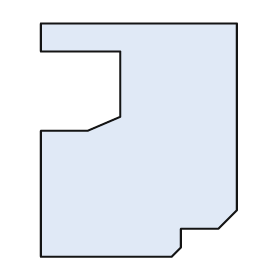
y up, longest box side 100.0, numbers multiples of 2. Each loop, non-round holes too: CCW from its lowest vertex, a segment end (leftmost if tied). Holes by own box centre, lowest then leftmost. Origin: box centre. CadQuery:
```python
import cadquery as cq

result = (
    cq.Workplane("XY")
    .moveTo(-42.0, -50.0)
    .lineTo(14.0, -50.0)
    .lineTo(18.0, -46.0)
    .lineTo(18.0, -38.0)
    .lineTo(34.0, -38.0)
    .lineTo(42.0, -30.0)
    .lineTo(42.0, 50.0)
    .lineTo(-42.0, 50.0)
    .lineTo(-42.0, 38.0)
    .lineTo(-8.0, 38.0)
    .lineTo(-8.0, 10.0)
    .lineTo(-22.0, 4.0)
    .lineTo(-42.0, 4.0)
    .close()
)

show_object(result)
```